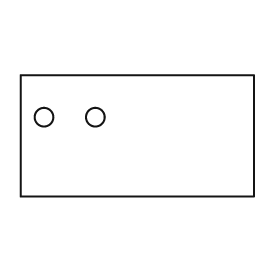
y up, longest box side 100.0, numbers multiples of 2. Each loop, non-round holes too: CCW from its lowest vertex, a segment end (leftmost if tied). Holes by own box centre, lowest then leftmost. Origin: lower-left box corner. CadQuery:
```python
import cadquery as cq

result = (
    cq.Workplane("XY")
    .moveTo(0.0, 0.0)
    .lineTo(100.0, 0.0)
    .lineTo(100.0, 52.0)
    .lineTo(0.0, 52.0)
    .close()
    .moveTo(10.0, 34.0)
    .circle(4.0)
    .moveTo(32.0, 34.0)
    .circle(4.0)
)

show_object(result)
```